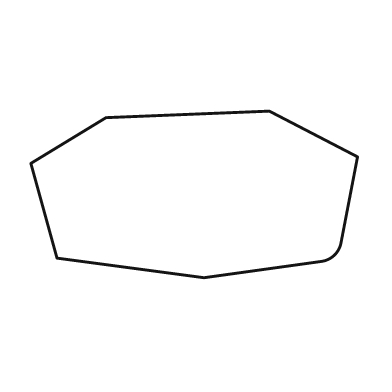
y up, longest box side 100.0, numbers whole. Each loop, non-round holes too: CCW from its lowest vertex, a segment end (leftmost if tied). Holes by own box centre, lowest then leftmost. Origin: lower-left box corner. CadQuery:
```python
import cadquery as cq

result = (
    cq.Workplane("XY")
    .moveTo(53.0, 0.0)
    .lineTo(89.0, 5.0)
    .threePointArc((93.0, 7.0), (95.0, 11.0))
    .lineTo(100.0, 37.0)
    .lineTo(73.0, 51.0)
    .lineTo(23.0, 49.0)
    .lineTo(0.0, 35.0)
    .lineTo(8.0, 6.0)
    .close()
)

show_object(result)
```